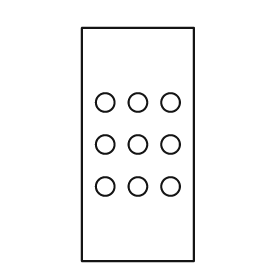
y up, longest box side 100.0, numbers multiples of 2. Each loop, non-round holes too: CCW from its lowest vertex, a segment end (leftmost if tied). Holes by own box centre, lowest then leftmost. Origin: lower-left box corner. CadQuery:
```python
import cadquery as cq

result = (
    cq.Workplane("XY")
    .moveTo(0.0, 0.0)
    .lineTo(48.0, 0.0)
    .lineTo(48.0, 100.0)
    .lineTo(0.0, 100.0)
    .close()
    .moveTo(10.0, 32.0)
    .circle(4.0)
    .moveTo(24.0, 32.0)
    .circle(4.0)
    .moveTo(38.0, 32.0)
    .circle(4.0)
    .moveTo(10.0, 50.0)
    .circle(4.0)
    .moveTo(24.0, 50.0)
    .circle(4.0)
    .moveTo(38.0, 50.0)
    .circle(4.0)
    .moveTo(10.0, 68.0)
    .circle(4.0)
    .moveTo(24.0, 68.0)
    .circle(4.0)
    .moveTo(38.0, 68.0)
    .circle(4.0)
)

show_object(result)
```